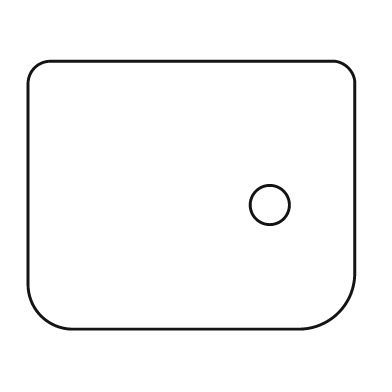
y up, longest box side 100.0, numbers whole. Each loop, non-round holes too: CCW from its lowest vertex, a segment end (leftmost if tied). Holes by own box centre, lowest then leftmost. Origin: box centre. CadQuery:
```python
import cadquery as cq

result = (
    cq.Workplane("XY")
    .moveTo(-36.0, -41.0)
    .lineTo(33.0, -41.0)
    .threePointArc((45.0, -36.0), (50.0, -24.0))
    .lineTo(50.0, 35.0)
    .threePointArc((48.0, 39.0), (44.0, 41.0))
    .lineTo(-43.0, 41.0)
    .threePointArc((-48.0, 39.0), (-50.0, 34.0))
    .lineTo(-50.0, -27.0)
    .threePointArc((-46.0, -37.0), (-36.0, -41.0))
    .close()
    .moveTo(24.0, -3.0)
    .circle(6.0)
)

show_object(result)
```